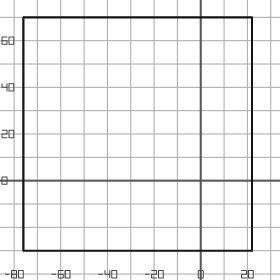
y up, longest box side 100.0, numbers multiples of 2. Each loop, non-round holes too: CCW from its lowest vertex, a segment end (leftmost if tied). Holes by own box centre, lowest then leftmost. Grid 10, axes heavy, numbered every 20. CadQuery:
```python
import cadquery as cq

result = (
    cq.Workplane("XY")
    .moveTo(-76.0, -30.0)
    .lineTo(22.0, -30.0)
    .lineTo(22.0, 70.0)
    .lineTo(-76.0, 70.0)
    .close()
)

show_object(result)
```